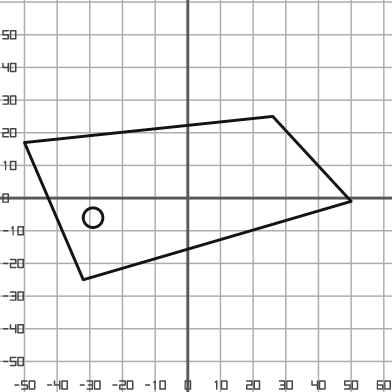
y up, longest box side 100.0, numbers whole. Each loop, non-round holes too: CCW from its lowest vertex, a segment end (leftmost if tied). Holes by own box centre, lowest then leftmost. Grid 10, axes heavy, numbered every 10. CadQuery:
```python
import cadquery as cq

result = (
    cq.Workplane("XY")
    .moveTo(-32.0, -25.0)
    .lineTo(50.0, -1.0)
    .lineTo(26.0, 25.0)
    .lineTo(-50.0, 17.0)
    .close()
    .moveTo(-29.0, -6.0)
    .circle(3.0)
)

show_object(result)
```